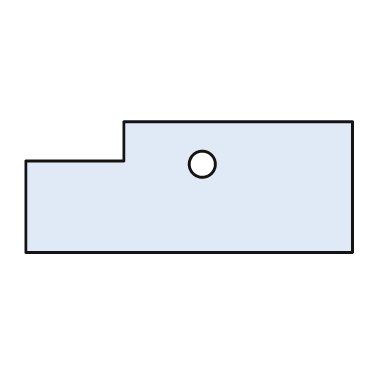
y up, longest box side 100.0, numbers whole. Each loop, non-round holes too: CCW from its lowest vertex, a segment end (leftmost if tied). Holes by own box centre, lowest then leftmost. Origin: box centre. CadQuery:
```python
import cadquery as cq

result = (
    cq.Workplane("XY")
    .moveTo(-50.0, -20.0)
    .lineTo(50.0, -20.0)
    .lineTo(50.0, 20.0)
    .lineTo(-20.0, 20.0)
    .lineTo(-20.0, 8.0)
    .lineTo(-50.0, 8.0)
    .close()
    .moveTo(4.0, 7.0)
    .circle(4.0)
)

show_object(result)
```